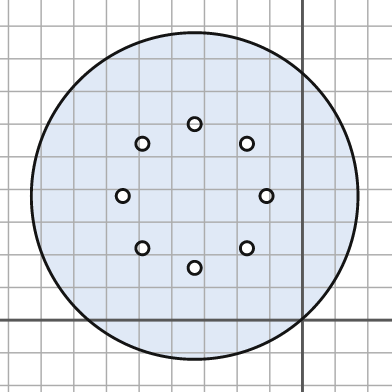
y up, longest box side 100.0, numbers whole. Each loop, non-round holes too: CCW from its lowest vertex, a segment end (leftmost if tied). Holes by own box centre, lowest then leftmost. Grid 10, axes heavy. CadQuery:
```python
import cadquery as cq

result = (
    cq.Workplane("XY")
    .moveTo(-33.0, 38.0)
    .circle(50.0)
    .moveTo(-33.0, 16.0)
    .circle(2.0)
    .moveTo(-49.0, 22.0)
    .circle(2.0)
    .moveTo(-17.0, 22.0)
    .circle(2.0)
    .moveTo(-55.0, 38.0)
    .circle(2.0)
    .moveTo(-11.0, 38.0)
    .circle(2.0)
    .moveTo(-49.0, 54.0)
    .circle(2.0)
    .moveTo(-17.0, 54.0)
    .circle(2.0)
    .moveTo(-33.0, 60.0)
    .circle(2.0)
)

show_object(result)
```